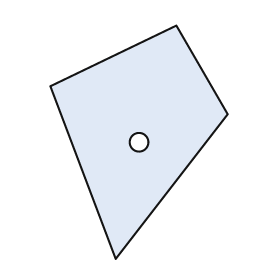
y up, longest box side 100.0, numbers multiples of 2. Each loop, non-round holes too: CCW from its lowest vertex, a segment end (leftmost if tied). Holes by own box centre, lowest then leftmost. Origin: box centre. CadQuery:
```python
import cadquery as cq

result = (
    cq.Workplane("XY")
    .moveTo(-10.0, -50.0)
    .lineTo(38.0, 12.0)
    .lineTo(16.0, 50.0)
    .lineTo(-38.0, 24.0)
    .close()
    .moveTo(0.0, 0.0)
    .circle(4.0)
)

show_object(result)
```